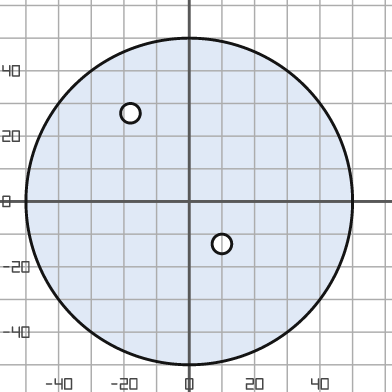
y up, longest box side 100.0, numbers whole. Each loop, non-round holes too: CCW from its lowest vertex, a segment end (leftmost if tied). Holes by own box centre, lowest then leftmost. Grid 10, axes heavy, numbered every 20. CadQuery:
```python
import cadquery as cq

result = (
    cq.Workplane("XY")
    .moveTo(0.0, 0.0)
    .circle(50.0)
    .moveTo(10.0, -13.0)
    .circle(3.0)
    .moveTo(-18.0, 27.0)
    .circle(3.0)
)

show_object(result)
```